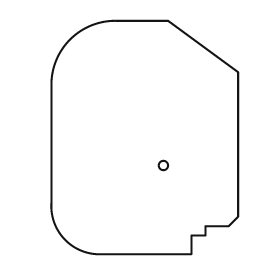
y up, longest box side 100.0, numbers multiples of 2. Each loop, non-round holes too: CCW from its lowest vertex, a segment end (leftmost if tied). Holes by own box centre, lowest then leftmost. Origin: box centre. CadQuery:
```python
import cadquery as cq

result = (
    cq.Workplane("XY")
    .moveTo(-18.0, -50.0)
    .lineTo(20.0, -50.0)
    .lineTo(20.0, -42.0)
    .lineTo(26.0, -42.0)
    .lineTo(26.0, -38.0)
    .lineTo(36.0, -38.0)
    .lineTo(40.0, -34.0)
    .lineTo(40.0, 28.0)
    .lineTo(10.0, 50.0)
    .lineTo(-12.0, 50.0)
    .threePointArc((-32.0, 42.0), (-40.0, 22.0))
    .lineTo(-40.0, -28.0)
    .threePointArc((-34.0, -44.0), (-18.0, -50.0))
    .close()
    .moveTo(8.0, -12.0)
    .circle(2.0)
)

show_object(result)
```